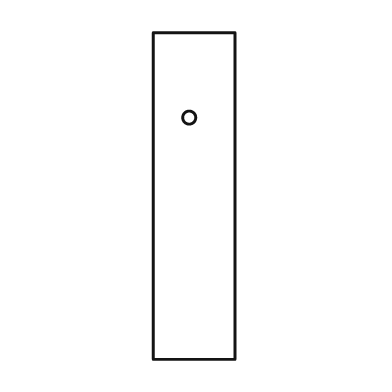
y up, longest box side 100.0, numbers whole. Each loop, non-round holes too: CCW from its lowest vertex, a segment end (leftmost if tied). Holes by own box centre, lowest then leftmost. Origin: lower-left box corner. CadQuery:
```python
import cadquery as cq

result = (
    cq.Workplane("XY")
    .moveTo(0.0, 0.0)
    .lineTo(25.0, 0.0)
    .lineTo(25.0, 100.0)
    .lineTo(0.0, 100.0)
    .close()
    .moveTo(11.0, 74.0)
    .circle(2.0)
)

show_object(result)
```